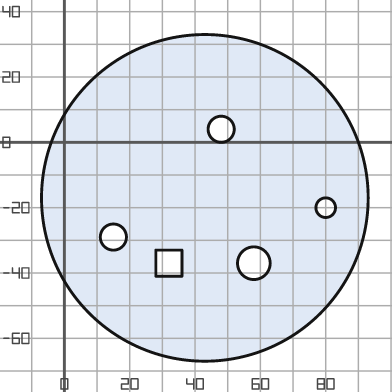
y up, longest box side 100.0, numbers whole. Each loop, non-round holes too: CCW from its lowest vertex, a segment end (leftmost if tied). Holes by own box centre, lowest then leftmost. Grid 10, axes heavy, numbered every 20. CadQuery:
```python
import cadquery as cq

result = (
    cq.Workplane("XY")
    .moveTo(43.0, -17.0)
    .circle(50.0)
    .moveTo(28.0, -41.0)
    .lineTo(36.0, -41.0)
    .lineTo(36.0, -33.0)
    .lineTo(28.0, -33.0)
    .close()
    .moveTo(58.0, -37.0)
    .circle(5.0)
    .moveTo(15.0, -29.0)
    .circle(4.0)
    .moveTo(80.0, -20.0)
    .circle(3.0)
    .moveTo(48.0, 4.0)
    .circle(4.0)
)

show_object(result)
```